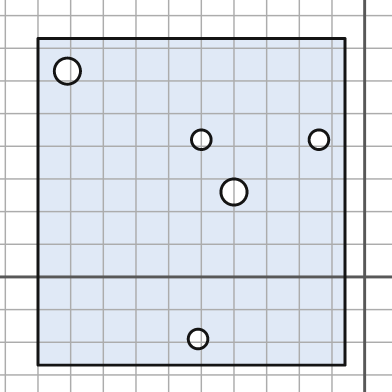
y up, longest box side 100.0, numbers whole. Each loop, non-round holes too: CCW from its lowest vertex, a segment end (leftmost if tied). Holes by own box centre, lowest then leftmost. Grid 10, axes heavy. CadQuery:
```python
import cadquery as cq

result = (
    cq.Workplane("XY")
    .moveTo(-100.0, -27.0)
    .lineTo(-6.0, -27.0)
    .lineTo(-6.0, 73.0)
    .lineTo(-100.0, 73.0)
    .close()
    .moveTo(-51.0, -19.0)
    .circle(3.0)
    .moveTo(-40.0, 26.0)
    .circle(4.0)
    .moveTo(-50.0, 42.0)
    .circle(3.0)
    .moveTo(-14.0, 42.0)
    .circle(3.0)
    .moveTo(-91.0, 63.0)
    .circle(4.0)
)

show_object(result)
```